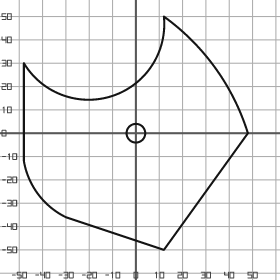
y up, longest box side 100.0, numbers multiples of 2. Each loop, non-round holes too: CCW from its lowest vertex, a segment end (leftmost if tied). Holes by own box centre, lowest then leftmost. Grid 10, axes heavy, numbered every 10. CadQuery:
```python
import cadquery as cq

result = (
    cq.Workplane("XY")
    .moveTo(12.0, -50.0)
    .lineTo(48.0, 0.0)
    .threePointArc((34.0, 28.0), (12.0, 50.0))
    .threePointArc((-10.0, 16.0), (-48.0, 30.0))
    .lineTo(-48.0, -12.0)
    .threePointArc((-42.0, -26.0), (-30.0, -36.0))
    .close()
    .moveTo(0.0, 0.0)
    .circle(4.0)
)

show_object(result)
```